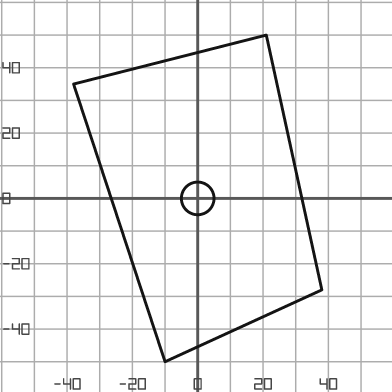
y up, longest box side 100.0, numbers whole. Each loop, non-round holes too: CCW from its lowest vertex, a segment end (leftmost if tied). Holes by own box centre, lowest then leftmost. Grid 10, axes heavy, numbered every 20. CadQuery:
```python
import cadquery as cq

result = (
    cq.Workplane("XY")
    .moveTo(-10.0, -50.0)
    .lineTo(38.0, -28.0)
    .lineTo(21.0, 50.0)
    .lineTo(-38.0, 35.0)
    .close()
    .moveTo(0.0, 0.0)
    .circle(5.0)
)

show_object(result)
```